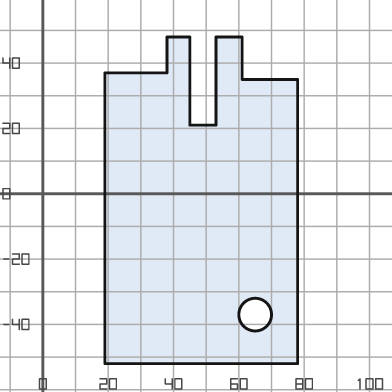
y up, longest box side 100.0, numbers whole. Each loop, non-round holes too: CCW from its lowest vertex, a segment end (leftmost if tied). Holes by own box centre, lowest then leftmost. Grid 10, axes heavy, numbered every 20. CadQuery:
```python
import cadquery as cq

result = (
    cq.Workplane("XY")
    .moveTo(19.0, -52.0)
    .lineTo(78.0, -52.0)
    .lineTo(78.0, 35.0)
    .lineTo(61.0, 35.0)
    .lineTo(61.0, 48.0)
    .lineTo(53.0, 48.0)
    .lineTo(53.0, 21.0)
    .lineTo(45.0, 21.0)
    .lineTo(45.0, 48.0)
    .lineTo(38.0, 48.0)
    .lineTo(38.0, 37.0)
    .lineTo(19.0, 37.0)
    .close()
    .moveTo(65.0, -37.0)
    .circle(5.0)
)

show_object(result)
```